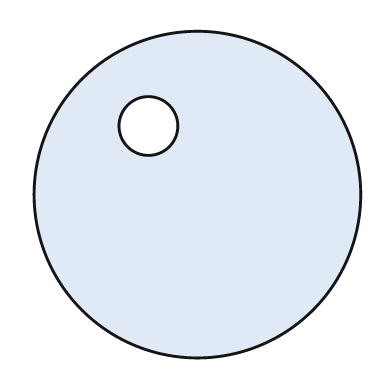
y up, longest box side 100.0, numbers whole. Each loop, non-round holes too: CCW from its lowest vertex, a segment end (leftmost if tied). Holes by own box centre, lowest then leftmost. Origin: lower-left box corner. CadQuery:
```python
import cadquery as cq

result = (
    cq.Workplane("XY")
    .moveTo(50.0, 50.0)
    .circle(50.0)
    .moveTo(35.0, 71.0)
    .circle(9.0)
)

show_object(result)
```